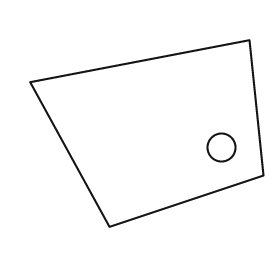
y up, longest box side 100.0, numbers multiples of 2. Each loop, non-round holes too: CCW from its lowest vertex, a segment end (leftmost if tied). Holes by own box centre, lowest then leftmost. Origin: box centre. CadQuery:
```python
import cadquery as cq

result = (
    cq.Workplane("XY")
    .moveTo(-16.0, -40.0)
    .lineTo(50.0, -18.0)
    .lineTo(44.0, 40.0)
    .lineTo(-50.0, 22.0)
    .close()
    .moveTo(32.0, -6.0)
    .circle(6.0)
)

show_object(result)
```